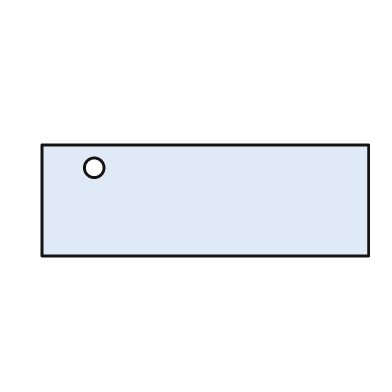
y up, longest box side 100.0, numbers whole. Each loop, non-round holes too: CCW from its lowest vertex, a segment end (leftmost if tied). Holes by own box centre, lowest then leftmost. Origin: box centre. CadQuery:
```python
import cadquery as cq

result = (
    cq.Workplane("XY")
    .moveTo(-50.0, -17.0)
    .lineTo(50.0, -17.0)
    .lineTo(50.0, 17.0)
    .lineTo(-50.0, 17.0)
    .close()
    .moveTo(-34.0, 10.0)
    .circle(3.0)
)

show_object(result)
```